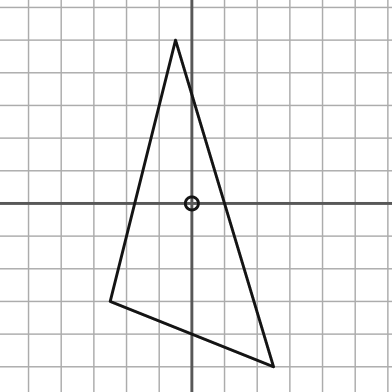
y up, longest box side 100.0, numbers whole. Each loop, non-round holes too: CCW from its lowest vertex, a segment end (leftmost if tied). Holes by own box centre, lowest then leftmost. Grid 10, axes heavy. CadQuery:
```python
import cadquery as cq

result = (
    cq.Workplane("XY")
    .moveTo(25.0, -50.0)
    .lineTo(-5.0, 50.0)
    .lineTo(-25.0, -30.0)
    .close()
    .moveTo(0.0, 0.0)
    .circle(2.0)
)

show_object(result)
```